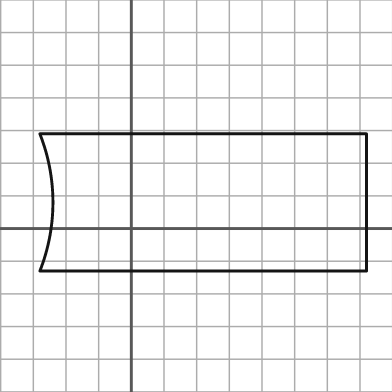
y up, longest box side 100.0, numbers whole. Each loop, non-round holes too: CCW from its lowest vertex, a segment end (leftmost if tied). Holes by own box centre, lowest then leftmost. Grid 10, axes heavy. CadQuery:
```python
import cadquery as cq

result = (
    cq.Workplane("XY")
    .moveTo(-28.0, -13.0)
    .lineTo(72.0, -13.0)
    .lineTo(72.0, 29.0)
    .lineTo(-28.0, 29.0)
    .threePointArc((-24.0, 8.0), (-28.0, -13.0))
    .close()
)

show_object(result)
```